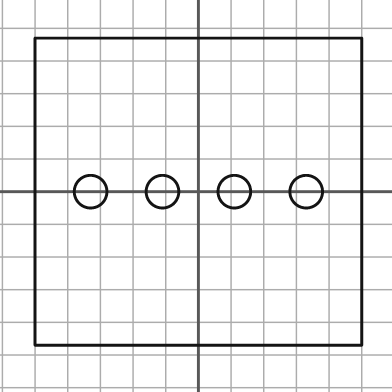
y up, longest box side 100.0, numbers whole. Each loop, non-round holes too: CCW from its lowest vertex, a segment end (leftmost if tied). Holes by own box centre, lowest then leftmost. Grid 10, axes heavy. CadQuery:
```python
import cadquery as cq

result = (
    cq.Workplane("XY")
    .moveTo(-50.0, -47.0)
    .lineTo(50.0, -47.0)
    .lineTo(50.0, 47.0)
    .lineTo(-50.0, 47.0)
    .close()
    .moveTo(-33.0, 0.0)
    .circle(5.0)
    .moveTo(-11.0, 0.0)
    .circle(5.0)
    .moveTo(11.0, 0.0)
    .circle(5.0)
    .moveTo(33.0, 0.0)
    .circle(5.0)
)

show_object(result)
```